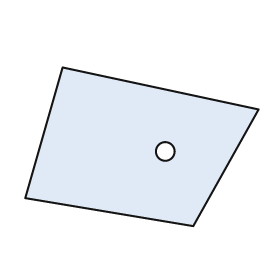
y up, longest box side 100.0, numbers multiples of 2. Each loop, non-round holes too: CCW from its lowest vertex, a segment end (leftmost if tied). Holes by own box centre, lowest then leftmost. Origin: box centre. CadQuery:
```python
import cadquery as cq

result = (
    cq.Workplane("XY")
    .moveTo(22.0, -34.0)
    .lineTo(50.0, 16.0)
    .lineTo(-34.0, 34.0)
    .lineTo(-50.0, -22.0)
    .close()
    .moveTo(10.0, -2.0)
    .circle(4.0)
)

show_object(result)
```